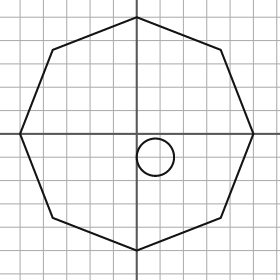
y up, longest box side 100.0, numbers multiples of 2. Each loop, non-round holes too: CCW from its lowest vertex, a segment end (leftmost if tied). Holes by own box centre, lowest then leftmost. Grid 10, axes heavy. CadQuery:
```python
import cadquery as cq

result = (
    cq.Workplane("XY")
    .moveTo(0.0, -50.0)
    .lineTo(36.0, -36.0)
    .lineTo(50.0, 0.0)
    .lineTo(36.0, 36.0)
    .lineTo(0.0, 50.0)
    .lineTo(-36.0, 36.0)
    .lineTo(-50.0, 0.0)
    .lineTo(-36.0, -36.0)
    .close()
    .moveTo(8.0, -10.0)
    .circle(8.0)
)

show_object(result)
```